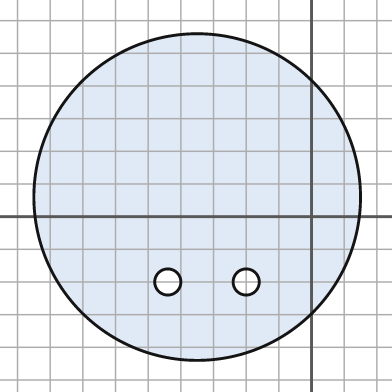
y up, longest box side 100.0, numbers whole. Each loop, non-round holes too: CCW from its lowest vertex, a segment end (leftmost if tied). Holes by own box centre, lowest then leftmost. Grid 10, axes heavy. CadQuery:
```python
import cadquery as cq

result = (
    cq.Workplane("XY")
    .moveTo(-35.0, 6.0)
    .circle(50.0)
    .moveTo(-44.0, -20.0)
    .circle(4.0)
    .moveTo(-20.0, -20.0)
    .circle(4.0)
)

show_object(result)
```